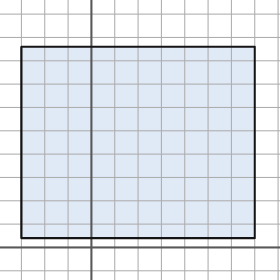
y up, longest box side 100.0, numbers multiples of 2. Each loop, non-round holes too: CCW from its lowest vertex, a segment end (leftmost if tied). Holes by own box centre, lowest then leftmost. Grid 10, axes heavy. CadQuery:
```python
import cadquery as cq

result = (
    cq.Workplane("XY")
    .moveTo(-30.0, 4.0)
    .lineTo(70.0, 4.0)
    .lineTo(70.0, 86.0)
    .lineTo(-30.0, 86.0)
    .close()
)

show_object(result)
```